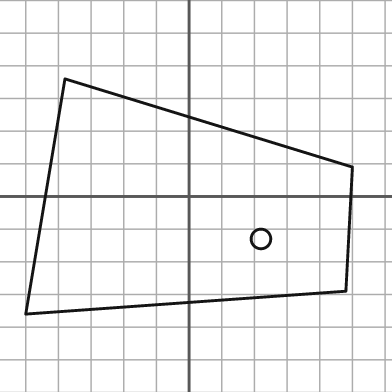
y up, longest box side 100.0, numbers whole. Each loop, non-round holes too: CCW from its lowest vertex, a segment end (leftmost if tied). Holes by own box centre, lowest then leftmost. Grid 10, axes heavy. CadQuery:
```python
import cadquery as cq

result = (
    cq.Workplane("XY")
    .moveTo(-50.0, -36.0)
    .lineTo(48.0, -29.0)
    .lineTo(50.0, 9.0)
    .lineTo(-38.0, 36.0)
    .close()
    .moveTo(22.0, -13.0)
    .circle(3.0)
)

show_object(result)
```